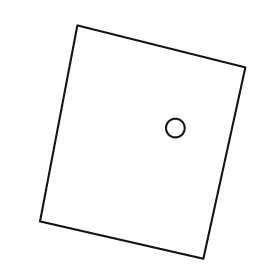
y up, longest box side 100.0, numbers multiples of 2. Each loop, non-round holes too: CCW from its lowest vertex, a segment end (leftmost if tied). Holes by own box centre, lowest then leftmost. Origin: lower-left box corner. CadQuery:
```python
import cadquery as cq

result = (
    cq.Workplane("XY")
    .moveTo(70.0, 0.0)
    .lineTo(88.0, 82.0)
    .lineTo(16.0, 100.0)
    .lineTo(0.0, 16.0)
    .close()
    .moveTo(58.0, 56.0)
    .circle(4.0)
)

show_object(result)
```